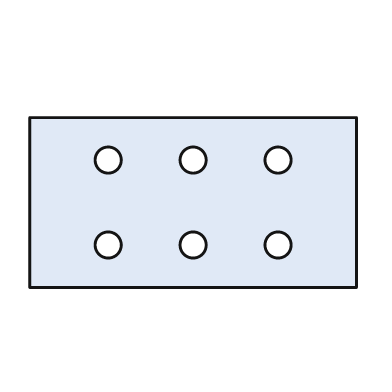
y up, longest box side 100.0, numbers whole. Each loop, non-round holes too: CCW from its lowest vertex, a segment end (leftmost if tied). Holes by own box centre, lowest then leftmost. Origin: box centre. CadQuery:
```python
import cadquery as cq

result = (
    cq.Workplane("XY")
    .moveTo(-50.0, -26.0)
    .lineTo(50.0, -26.0)
    .lineTo(50.0, 26.0)
    .lineTo(-50.0, 26.0)
    .close()
    .moveTo(-26.0, -13.0)
    .circle(4.0)
    .moveTo(0.0, -13.0)
    .circle(4.0)
    .moveTo(26.0, -13.0)
    .circle(4.0)
    .moveTo(-26.0, 13.0)
    .circle(4.0)
    .moveTo(0.0, 13.0)
    .circle(4.0)
    .moveTo(26.0, 13.0)
    .circle(4.0)
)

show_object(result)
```